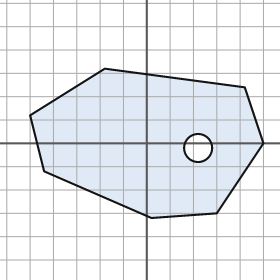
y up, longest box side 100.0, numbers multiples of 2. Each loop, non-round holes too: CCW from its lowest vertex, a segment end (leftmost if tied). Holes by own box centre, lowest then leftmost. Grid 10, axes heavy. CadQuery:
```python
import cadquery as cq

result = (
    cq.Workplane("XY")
    .moveTo(2.0, -32.0)
    .lineTo(30.0, -30.0)
    .lineTo(50.0, 0.0)
    .lineTo(42.0, 24.0)
    .lineTo(-18.0, 32.0)
    .lineTo(-50.0, 12.0)
    .lineTo(-44.0, -12.0)
    .close()
    .moveTo(22.0, -2.0)
    .circle(6.0)
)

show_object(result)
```